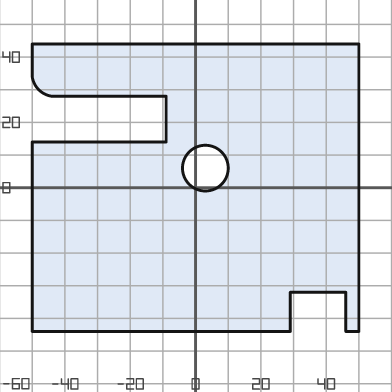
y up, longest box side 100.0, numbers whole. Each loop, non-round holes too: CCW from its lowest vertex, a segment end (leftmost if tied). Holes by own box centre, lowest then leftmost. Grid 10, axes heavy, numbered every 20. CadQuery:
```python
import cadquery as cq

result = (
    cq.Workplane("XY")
    .moveTo(-50.0, -44.0)
    .lineTo(29.0, -44.0)
    .lineTo(29.0, -32.0)
    .lineTo(46.0, -32.0)
    .lineTo(46.0, -44.0)
    .lineTo(50.0, -44.0)
    .lineTo(50.0, 44.0)
    .lineTo(-50.0, 44.0)
    .lineTo(-50.0, 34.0)
    .threePointArc((-48.0, 30.0), (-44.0, 28.0))
    .lineTo(-9.0, 28.0)
    .lineTo(-9.0, 14.0)
    .lineTo(-50.0, 14.0)
    .close()
    .moveTo(3.0, 6.0)
    .circle(7.0)
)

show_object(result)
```